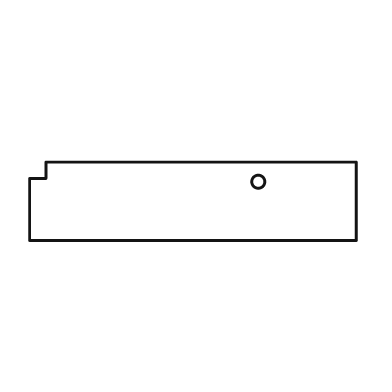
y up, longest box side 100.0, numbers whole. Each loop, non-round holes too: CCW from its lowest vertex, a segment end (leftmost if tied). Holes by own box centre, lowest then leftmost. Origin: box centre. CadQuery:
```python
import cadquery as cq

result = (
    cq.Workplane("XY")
    .moveTo(-50.0, -12.0)
    .lineTo(50.0, -12.0)
    .lineTo(50.0, 12.0)
    .lineTo(-45.0, 12.0)
    .lineTo(-45.0, 7.0)
    .lineTo(-50.0, 7.0)
    .close()
    .moveTo(20.0, 6.0)
    .circle(2.0)
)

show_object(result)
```